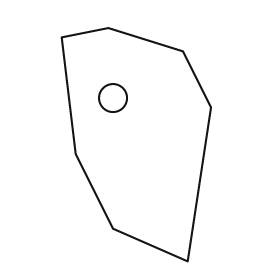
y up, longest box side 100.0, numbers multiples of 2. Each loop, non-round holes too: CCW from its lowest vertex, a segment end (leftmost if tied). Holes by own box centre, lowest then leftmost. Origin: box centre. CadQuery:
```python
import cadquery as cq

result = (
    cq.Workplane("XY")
    .moveTo(22.0, -50.0)
    .lineTo(32.0, 16.0)
    .lineTo(20.0, 40.0)
    .lineTo(-12.0, 50.0)
    .lineTo(-32.0, 46.0)
    .lineTo(-26.0, -4.0)
    .lineTo(-10.0, -36.0)
    .close()
    .moveTo(-10.0, 20.0)
    .circle(6.0)
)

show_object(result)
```